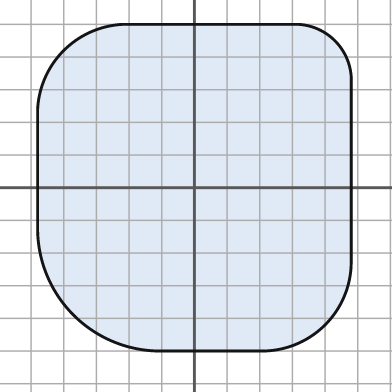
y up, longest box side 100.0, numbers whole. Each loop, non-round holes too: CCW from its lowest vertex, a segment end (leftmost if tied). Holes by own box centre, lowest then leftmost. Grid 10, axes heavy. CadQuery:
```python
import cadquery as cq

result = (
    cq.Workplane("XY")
    .moveTo(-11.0, -50.0)
    .lineTo(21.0, -50.0)
    .threePointArc((40.0, -42.0), (48.0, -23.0))
    .lineTo(48.0, 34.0)
    .threePointArc((43.0, 45.0), (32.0, 50.0))
    .lineTo(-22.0, 50.0)
    .threePointArc((-40.0, 42.0), (-48.0, 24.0))
    .lineTo(-48.0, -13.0)
    .threePointArc((-37.0, -39.0), (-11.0, -50.0))
    .close()
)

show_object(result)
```